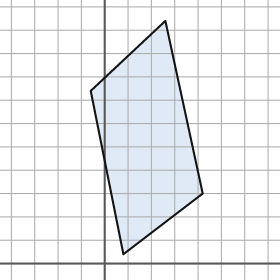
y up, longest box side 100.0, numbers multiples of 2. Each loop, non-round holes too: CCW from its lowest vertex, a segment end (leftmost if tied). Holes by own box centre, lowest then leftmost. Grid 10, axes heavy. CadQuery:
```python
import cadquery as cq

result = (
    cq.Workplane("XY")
    .moveTo(8.0, 4.0)
    .lineTo(42.0, 30.0)
    .lineTo(26.0, 104.0)
    .lineTo(-6.0, 74.0)
    .close()
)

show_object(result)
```